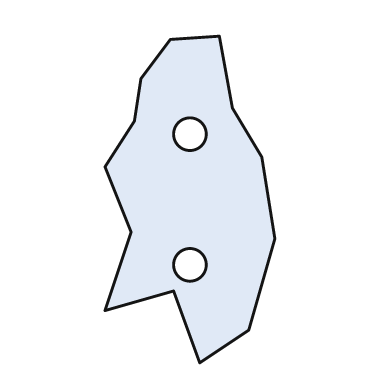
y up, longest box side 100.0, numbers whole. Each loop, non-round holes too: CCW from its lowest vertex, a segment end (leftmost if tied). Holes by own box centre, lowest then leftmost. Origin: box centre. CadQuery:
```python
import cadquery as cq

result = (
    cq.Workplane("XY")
    .moveTo(3.0, -50.0)
    .lineTo(18.0, -40.0)
    .lineTo(26.0, -12.0)
    .lineTo(22.0, 13.0)
    .lineTo(13.0, 28.0)
    .lineTo(9.0, 50.0)
    .lineTo(-6.0, 49.0)
    .lineTo(-15.0, 37.0)
    .lineTo(-17.0, 24.0)
    .lineTo(-26.0, 10.0)
    .lineTo(-18.0, -10.0)
    .lineTo(-26.0, -34.0)
    .lineTo(-5.0, -28.0)
    .close()
    .moveTo(0.0, -20.0)
    .circle(5.0)
    .moveTo(0.0, 20.0)
    .circle(5.0)
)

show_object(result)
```